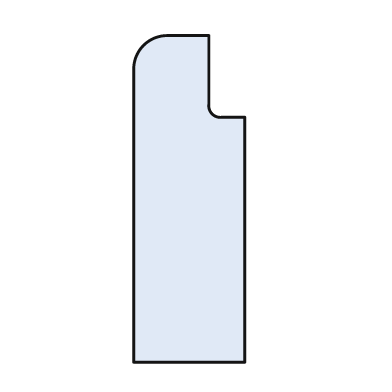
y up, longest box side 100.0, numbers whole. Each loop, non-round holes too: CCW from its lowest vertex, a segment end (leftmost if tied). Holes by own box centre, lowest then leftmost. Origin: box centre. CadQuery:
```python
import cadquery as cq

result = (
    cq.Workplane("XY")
    .moveTo(-17.0, -50.0)
    .lineTo(17.0, -50.0)
    .lineTo(17.0, 25.0)
    .lineTo(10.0, 25.0)
    .threePointArc((7.0, 26.0), (6.0, 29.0))
    .lineTo(6.0, 50.0)
    .lineTo(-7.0, 50.0)
    .threePointArc((-14.0, 47.0), (-17.0, 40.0))
    .close()
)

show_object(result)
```